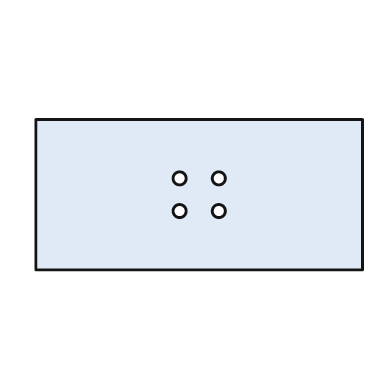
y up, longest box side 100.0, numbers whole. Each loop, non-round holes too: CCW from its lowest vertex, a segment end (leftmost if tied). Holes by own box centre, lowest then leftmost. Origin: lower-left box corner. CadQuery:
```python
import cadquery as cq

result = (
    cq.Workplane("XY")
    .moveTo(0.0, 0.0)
    .lineTo(100.0, 0.0)
    .lineTo(100.0, 46.0)
    .lineTo(0.0, 46.0)
    .close()
    .moveTo(44.0, 18.0)
    .circle(2.0)
    .moveTo(56.0, 18.0)
    .circle(2.0)
    .moveTo(44.0, 28.0)
    .circle(2.0)
    .moveTo(56.0, 28.0)
    .circle(2.0)
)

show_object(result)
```